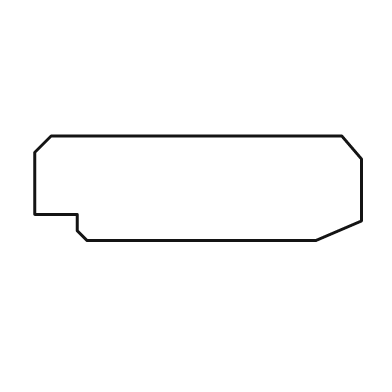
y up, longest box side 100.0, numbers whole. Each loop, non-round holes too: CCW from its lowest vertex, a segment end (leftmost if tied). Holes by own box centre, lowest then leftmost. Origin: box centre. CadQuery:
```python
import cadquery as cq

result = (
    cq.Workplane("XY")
    .moveTo(-34.0, -16.0)
    .lineTo(36.0, -16.0)
    .lineTo(50.0, -10.0)
    .lineTo(50.0, 9.0)
    .lineTo(44.0, 16.0)
    .lineTo(-45.0, 16.0)
    .lineTo(-50.0, 11.0)
    .lineTo(-50.0, -8.0)
    .lineTo(-37.0, -8.0)
    .lineTo(-37.0, -13.0)
    .close()
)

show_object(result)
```